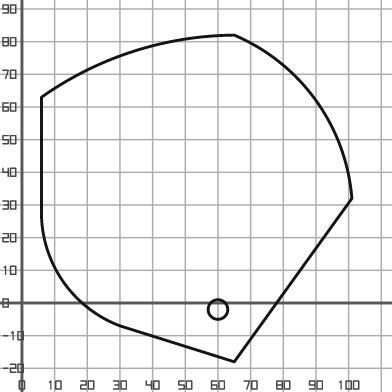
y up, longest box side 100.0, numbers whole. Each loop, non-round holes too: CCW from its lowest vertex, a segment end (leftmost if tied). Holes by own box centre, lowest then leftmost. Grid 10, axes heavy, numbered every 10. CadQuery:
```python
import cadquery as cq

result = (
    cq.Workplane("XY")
    .moveTo(65.0, -18.0)
    .lineTo(101.0, 32.0)
    .threePointArc((90.0, 62.0), (65.0, 82.0))
    .threePointArc((34.0, 77.0), (6.0, 63.0))
    .lineTo(6.0, 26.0)
    .threePointArc((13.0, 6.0), (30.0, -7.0))
    .close()
    .moveTo(60.0, -2.0)
    .circle(3.0)
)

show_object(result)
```